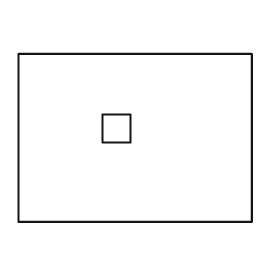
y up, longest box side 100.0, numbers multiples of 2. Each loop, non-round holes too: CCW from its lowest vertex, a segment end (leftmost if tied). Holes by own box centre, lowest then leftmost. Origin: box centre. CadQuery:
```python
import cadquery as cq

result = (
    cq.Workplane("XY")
    .moveTo(-50.0, -36.0)
    .lineTo(50.0, -36.0)
    .lineTo(50.0, 36.0)
    .lineTo(-50.0, 36.0)
    .close()
    .moveTo(-14.0, -2.0)
    .lineTo(-2.0, -2.0)
    .lineTo(-2.0, 10.0)
    .lineTo(-14.0, 10.0)
    .close()
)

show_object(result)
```